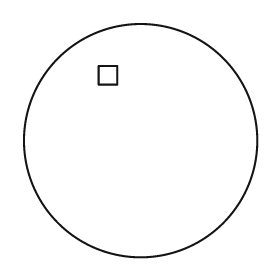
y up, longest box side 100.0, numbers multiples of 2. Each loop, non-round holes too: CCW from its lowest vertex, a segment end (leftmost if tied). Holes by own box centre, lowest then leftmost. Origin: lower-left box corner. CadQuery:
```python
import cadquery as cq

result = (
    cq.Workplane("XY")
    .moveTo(50.0, 50.0)
    .circle(50.0)
    .moveTo(32.0, 74.0)
    .lineTo(40.0, 74.0)
    .lineTo(40.0, 82.0)
    .lineTo(32.0, 82.0)
    .close()
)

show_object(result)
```